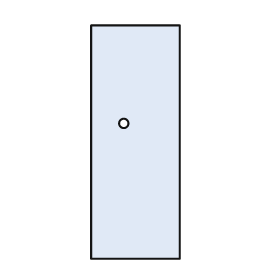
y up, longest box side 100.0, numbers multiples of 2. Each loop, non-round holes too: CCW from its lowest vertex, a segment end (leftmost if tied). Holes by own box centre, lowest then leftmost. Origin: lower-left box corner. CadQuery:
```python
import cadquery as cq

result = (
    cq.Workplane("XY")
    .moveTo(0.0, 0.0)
    .lineTo(38.0, 0.0)
    .lineTo(38.0, 100.0)
    .lineTo(0.0, 100.0)
    .close()
    .moveTo(14.0, 58.0)
    .circle(2.0)
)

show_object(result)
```